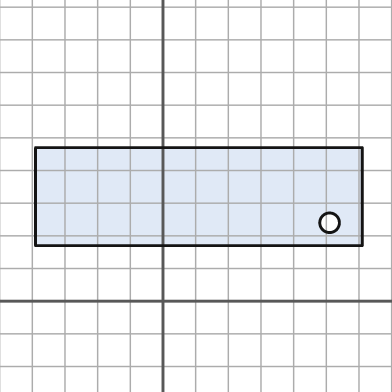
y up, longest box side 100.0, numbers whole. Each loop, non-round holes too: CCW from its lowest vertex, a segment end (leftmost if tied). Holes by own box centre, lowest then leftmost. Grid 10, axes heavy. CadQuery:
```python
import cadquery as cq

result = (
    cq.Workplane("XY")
    .moveTo(-39.0, 17.0)
    .lineTo(61.0, 17.0)
    .lineTo(61.0, 47.0)
    .lineTo(-39.0, 47.0)
    .close()
    .moveTo(51.0, 24.0)
    .circle(3.0)
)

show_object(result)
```